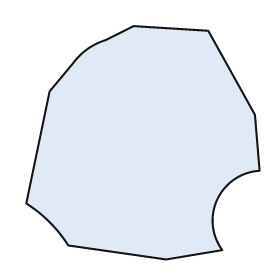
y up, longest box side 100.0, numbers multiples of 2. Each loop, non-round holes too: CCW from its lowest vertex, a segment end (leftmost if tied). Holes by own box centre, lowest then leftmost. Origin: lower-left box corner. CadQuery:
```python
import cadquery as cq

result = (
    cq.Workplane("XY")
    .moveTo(60.0, 0.0)
    .lineTo(84.0, 4.0)
    .threePointArc((82.0, 26.0), (100.0, 38.0))
    .lineTo(98.0, 62.0)
    .lineTo(78.0, 98.0)
    .lineTo(46.0, 100.0)
    .lineTo(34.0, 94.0)
    .threePointArc((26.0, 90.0), (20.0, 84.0))
    .lineTo(10.0, 72.0)
    .lineTo(0.0, 24.0)
    .threePointArc((10.0, 16.0), (18.0, 6.0))
    .close()
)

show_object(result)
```